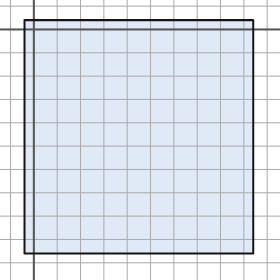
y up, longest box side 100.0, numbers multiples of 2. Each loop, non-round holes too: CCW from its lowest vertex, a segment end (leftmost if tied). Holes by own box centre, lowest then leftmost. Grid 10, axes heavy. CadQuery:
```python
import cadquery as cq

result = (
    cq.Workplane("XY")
    .moveTo(-4.0, -96.0)
    .lineTo(94.0, -96.0)
    .lineTo(94.0, 4.0)
    .lineTo(-4.0, 4.0)
    .close()
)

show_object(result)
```